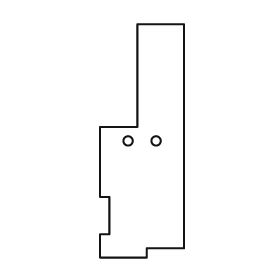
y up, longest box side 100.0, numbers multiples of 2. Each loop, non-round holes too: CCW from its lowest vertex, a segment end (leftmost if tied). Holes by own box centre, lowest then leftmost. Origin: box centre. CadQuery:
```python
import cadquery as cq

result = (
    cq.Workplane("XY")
    .moveTo(-18.0, -50.0)
    .lineTo(2.0, -50.0)
    .lineTo(2.0, -46.0)
    .lineTo(18.0, -46.0)
    .lineTo(18.0, 50.0)
    .lineTo(-2.0, 50.0)
    .lineTo(-2.0, 6.0)
    .lineTo(-18.0, 6.0)
    .lineTo(-18.0, -24.0)
    .lineTo(-14.0, -24.0)
    .lineTo(-14.0, -40.0)
    .lineTo(-18.0, -40.0)
    .close()
    .moveTo(-6.0, 0.0)
    .circle(2.0)
    .moveTo(6.0, 0.0)
    .circle(2.0)
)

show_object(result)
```